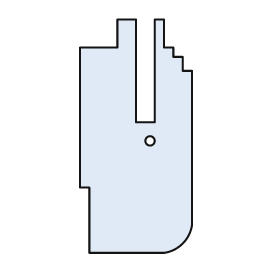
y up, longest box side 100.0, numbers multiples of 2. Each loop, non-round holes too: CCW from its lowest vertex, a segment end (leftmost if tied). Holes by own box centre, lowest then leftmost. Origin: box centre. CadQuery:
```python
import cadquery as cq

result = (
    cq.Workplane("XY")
    .moveTo(-20.0, -50.0)
    .lineTo(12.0, -50.0)
    .threePointArc((20.0, -46.0), (24.0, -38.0))
    .lineTo(24.0, 28.0)
    .lineTo(20.0, 28.0)
    .lineTo(20.0, 34.0)
    .lineTo(16.0, 34.0)
    .lineTo(16.0, 38.0)
    .lineTo(12.0, 38.0)
    .lineTo(12.0, 50.0)
    .lineTo(8.0, 50.0)
    .lineTo(8.0, 6.0)
    .lineTo(0.0, 6.0)
    .lineTo(0.0, 50.0)
    .lineTo(-8.0, 50.0)
    .lineTo(-8.0, 38.0)
    .lineTo(-24.0, 38.0)
    .lineTo(-24.0, -22.0)
    .lineTo(-20.0, -22.0)
    .close()
    .moveTo(6.0, -2.0)
    .circle(2.0)
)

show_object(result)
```